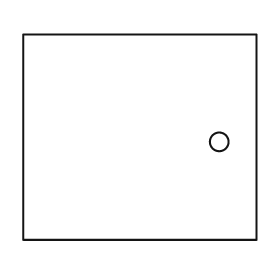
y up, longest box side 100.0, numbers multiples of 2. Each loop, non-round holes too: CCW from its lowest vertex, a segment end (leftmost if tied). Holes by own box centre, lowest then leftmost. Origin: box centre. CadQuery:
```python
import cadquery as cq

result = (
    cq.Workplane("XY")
    .moveTo(-50.0, -44.0)
    .lineTo(50.0, -44.0)
    .lineTo(50.0, 44.0)
    .lineTo(-50.0, 44.0)
    .close()
    .moveTo(34.0, -2.0)
    .circle(4.0)
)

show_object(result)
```